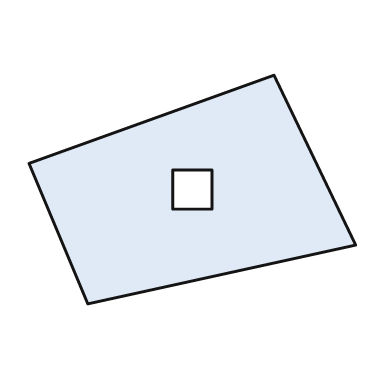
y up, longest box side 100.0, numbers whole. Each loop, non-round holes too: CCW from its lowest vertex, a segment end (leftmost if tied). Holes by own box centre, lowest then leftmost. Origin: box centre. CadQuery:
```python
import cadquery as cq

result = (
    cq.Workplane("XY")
    .moveTo(-32.0, -35.0)
    .lineTo(50.0, -17.0)
    .lineTo(25.0, 35.0)
    .lineTo(-50.0, 8.0)
    .close()
    .moveTo(-6.0, -6.0)
    .lineTo(6.0, -6.0)
    .lineTo(6.0, 6.0)
    .lineTo(-6.0, 6.0)
    .close()
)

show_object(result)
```